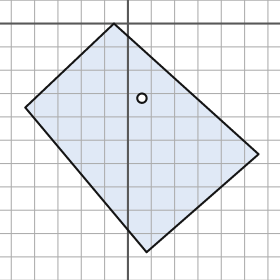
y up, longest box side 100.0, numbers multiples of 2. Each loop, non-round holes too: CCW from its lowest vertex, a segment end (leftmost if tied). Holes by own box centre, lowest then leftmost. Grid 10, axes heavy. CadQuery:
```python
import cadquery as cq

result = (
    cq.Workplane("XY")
    .moveTo(8.0, -98.0)
    .lineTo(56.0, -56.0)
    .lineTo(-6.0, 0.0)
    .lineTo(-44.0, -36.0)
    .close()
    .moveTo(6.0, -32.0)
    .circle(2.0)
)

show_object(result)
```